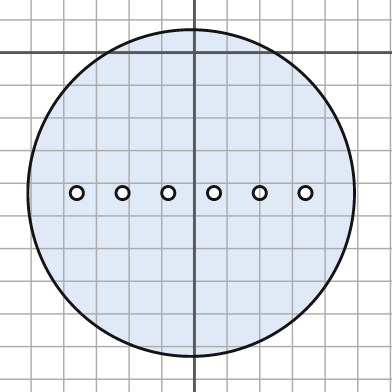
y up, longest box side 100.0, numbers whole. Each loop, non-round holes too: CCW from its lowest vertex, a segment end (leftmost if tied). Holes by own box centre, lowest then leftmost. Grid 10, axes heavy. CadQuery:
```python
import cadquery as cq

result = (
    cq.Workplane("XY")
    .moveTo(-1.0, -43.0)
    .circle(50.0)
    .moveTo(-36.0, -43.0)
    .circle(2.0)
    .moveTo(-22.0, -43.0)
    .circle(2.0)
    .moveTo(-8.0, -43.0)
    .circle(2.0)
    .moveTo(6.0, -43.0)
    .circle(2.0)
    .moveTo(20.0, -43.0)
    .circle(2.0)
    .moveTo(34.0, -43.0)
    .circle(2.0)
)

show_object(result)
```